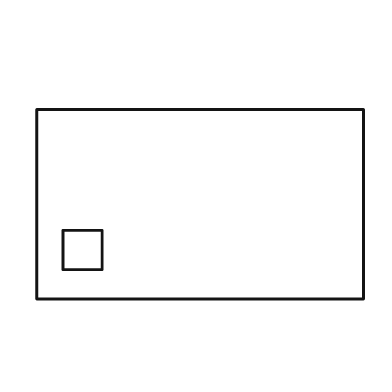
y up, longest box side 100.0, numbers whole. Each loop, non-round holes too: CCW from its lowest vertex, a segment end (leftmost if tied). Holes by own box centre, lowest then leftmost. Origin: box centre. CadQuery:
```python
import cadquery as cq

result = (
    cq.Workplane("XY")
    .moveTo(-50.0, -29.0)
    .lineTo(50.0, -29.0)
    .lineTo(50.0, 29.0)
    .lineTo(-50.0, 29.0)
    .close()
    .moveTo(-42.0, -20.0)
    .lineTo(-30.0, -20.0)
    .lineTo(-30.0, -8.0)
    .lineTo(-42.0, -8.0)
    .close()
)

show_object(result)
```